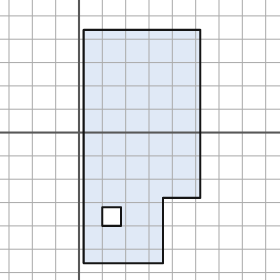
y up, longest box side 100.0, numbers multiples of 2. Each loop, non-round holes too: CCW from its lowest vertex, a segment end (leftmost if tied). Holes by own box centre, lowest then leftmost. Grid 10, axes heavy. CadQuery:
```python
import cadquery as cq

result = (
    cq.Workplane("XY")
    .moveTo(2.0, -56.0)
    .lineTo(36.0, -56.0)
    .lineTo(36.0, -28.0)
    .lineTo(52.0, -28.0)
    .lineTo(52.0, 44.0)
    .lineTo(2.0, 44.0)
    .close()
    .moveTo(10.0, -40.0)
    .lineTo(18.0, -40.0)
    .lineTo(18.0, -32.0)
    .lineTo(10.0, -32.0)
    .close()
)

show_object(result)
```